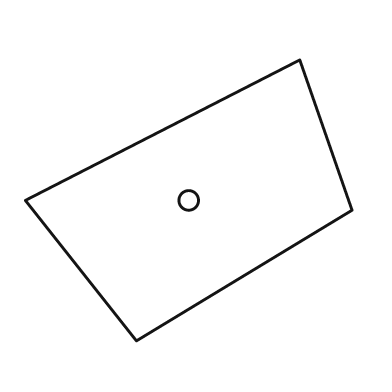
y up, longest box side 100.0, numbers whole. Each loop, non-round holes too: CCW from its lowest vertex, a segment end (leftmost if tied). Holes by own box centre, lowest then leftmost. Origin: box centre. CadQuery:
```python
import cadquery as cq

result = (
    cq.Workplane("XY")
    .moveTo(-16.0, -43.0)
    .lineTo(50.0, -3.0)
    .lineTo(34.0, 43.0)
    .lineTo(-50.0, 0.0)
    .close()
    .moveTo(0.0, 0.0)
    .circle(3.0)
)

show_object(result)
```